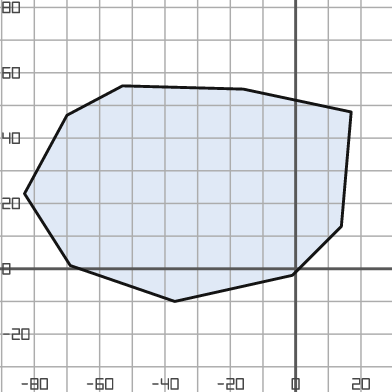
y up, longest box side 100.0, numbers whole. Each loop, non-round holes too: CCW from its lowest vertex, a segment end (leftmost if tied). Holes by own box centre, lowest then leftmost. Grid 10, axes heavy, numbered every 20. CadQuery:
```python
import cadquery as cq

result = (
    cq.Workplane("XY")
    .moveTo(-37.0, -10.0)
    .lineTo(-1.0, -2.0)
    .lineTo(14.0, 13.0)
    .lineTo(17.0, 48.0)
    .lineTo(-16.0, 55.0)
    .lineTo(-53.0, 56.0)
    .lineTo(-70.0, 47.0)
    .lineTo(-83.0, 23.0)
    .lineTo(-69.0, 1.0)
    .close()
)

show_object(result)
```